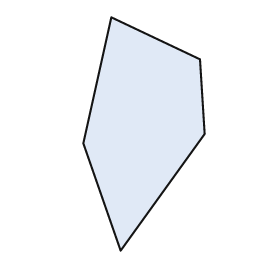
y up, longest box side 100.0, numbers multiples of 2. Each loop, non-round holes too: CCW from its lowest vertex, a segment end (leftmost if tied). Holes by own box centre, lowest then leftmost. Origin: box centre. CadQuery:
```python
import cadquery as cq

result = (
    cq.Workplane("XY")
    .moveTo(-10.0, -50.0)
    .lineTo(26.0, 0.0)
    .lineTo(24.0, 32.0)
    .lineTo(-14.0, 50.0)
    .lineTo(-26.0, -4.0)
    .close()
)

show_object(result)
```